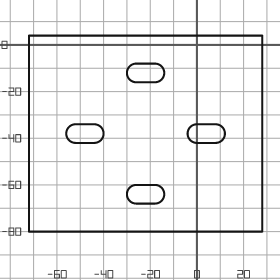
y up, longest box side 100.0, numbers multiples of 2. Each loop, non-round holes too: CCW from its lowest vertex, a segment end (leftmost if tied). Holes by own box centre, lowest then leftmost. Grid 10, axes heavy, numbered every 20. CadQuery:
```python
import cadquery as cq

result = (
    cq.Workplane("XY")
    .moveTo(-72.0, -80.0)
    .lineTo(28.0, -80.0)
    .lineTo(28.0, 4.0)
    .lineTo(-72.0, 4.0)
    .close()
    .moveTo(-26.0, -68.0)
    .lineTo(-18.0, -68.0)
    .threePointArc((-14.0, -64.0), (-18.0, -60.0))
    .lineTo(-26.0, -60.0)
    .threePointArc((-30.0, -64.0), (-26.0, -68.0))
    .close()
    .moveTo(-52.0, -42.0)
    .lineTo(-44.0, -42.0)
    .threePointArc((-40.0, -38.0), (-44.0, -34.0))
    .lineTo(-52.0, -34.0)
    .threePointArc((-56.0, -38.0), (-52.0, -42.0))
    .close()
    .moveTo(0.0, -42.0)
    .lineTo(8.0, -42.0)
    .threePointArc((12.0, -38.0), (8.0, -34.0))
    .lineTo(0.0, -34.0)
    .threePointArc((-4.0, -38.0), (0.0, -42.0))
    .close()
    .moveTo(-26.0, -16.0)
    .lineTo(-18.0, -16.0)
    .threePointArc((-14.0, -12.0), (-18.0, -8.0))
    .lineTo(-26.0, -8.0)
    .threePointArc((-30.0, -12.0), (-26.0, -16.0))
    .close()
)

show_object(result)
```